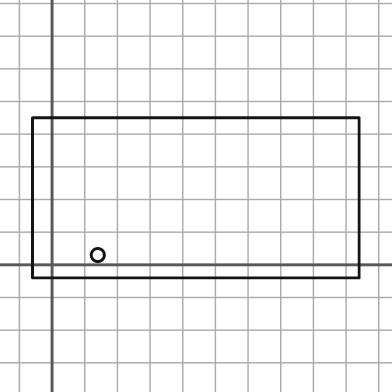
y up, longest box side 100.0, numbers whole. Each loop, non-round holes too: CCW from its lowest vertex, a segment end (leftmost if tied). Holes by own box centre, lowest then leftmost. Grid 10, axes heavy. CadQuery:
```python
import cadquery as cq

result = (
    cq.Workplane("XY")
    .moveTo(-6.0, -4.0)
    .lineTo(94.0, -4.0)
    .lineTo(94.0, 45.0)
    .lineTo(-6.0, 45.0)
    .close()
    .moveTo(14.0, 3.0)
    .circle(2.0)
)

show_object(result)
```